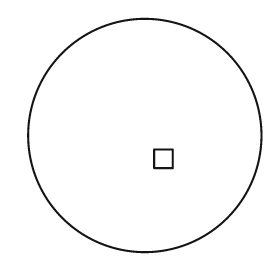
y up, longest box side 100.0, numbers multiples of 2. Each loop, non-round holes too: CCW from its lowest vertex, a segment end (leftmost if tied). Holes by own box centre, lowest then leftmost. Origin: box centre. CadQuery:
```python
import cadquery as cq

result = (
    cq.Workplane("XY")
    .moveTo(0.0, 0.0)
    .circle(50.0)
    .moveTo(4.0, -14.0)
    .lineTo(12.0, -14.0)
    .lineTo(12.0, -6.0)
    .lineTo(4.0, -6.0)
    .close()
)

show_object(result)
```